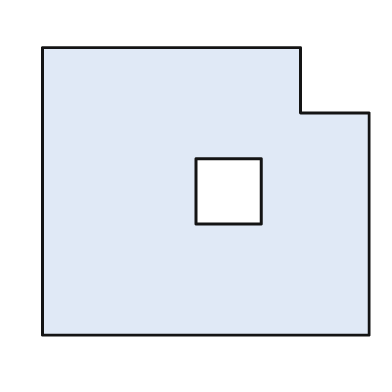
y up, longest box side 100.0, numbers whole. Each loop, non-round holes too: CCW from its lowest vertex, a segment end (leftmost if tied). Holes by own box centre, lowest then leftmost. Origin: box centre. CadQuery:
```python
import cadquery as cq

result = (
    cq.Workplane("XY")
    .moveTo(-50.0, -44.0)
    .lineTo(50.0, -44.0)
    .lineTo(50.0, 24.0)
    .lineTo(29.0, 24.0)
    .lineTo(29.0, 44.0)
    .lineTo(-50.0, 44.0)
    .close()
    .moveTo(-3.0, -10.0)
    .lineTo(17.0, -10.0)
    .lineTo(17.0, 10.0)
    .lineTo(-3.0, 10.0)
    .close()
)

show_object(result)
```